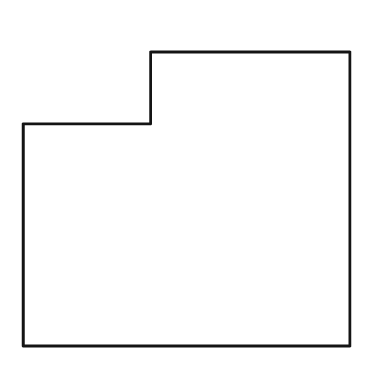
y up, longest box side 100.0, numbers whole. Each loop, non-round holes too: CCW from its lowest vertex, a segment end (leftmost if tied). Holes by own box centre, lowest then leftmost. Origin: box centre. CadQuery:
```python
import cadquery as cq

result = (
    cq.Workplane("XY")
    .moveTo(-50.0, -45.0)
    .lineTo(50.0, -45.0)
    .lineTo(50.0, 45.0)
    .lineTo(-11.0, 45.0)
    .lineTo(-11.0, 23.0)
    .lineTo(-50.0, 23.0)
    .close()
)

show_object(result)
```